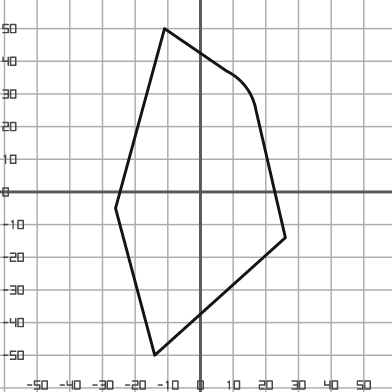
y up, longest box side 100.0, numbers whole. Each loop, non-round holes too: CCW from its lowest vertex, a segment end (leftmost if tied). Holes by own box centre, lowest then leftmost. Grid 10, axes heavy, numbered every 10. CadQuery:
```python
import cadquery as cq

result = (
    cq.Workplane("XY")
    .moveTo(-14.0, -50.0)
    .lineTo(26.0, -14.0)
    .lineTo(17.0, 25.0)
    .threePointArc((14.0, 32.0), (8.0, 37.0))
    .lineTo(-11.0, 50.0)
    .lineTo(-26.0, -5.0)
    .close()
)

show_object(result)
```